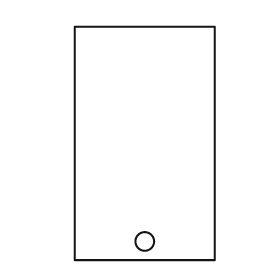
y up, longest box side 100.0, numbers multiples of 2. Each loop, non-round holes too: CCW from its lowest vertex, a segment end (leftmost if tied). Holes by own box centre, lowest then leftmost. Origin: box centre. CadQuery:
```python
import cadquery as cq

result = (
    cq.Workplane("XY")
    .moveTo(-30.0, -50.0)
    .lineTo(30.0, -50.0)
    .lineTo(30.0, 50.0)
    .lineTo(-30.0, 50.0)
    .close()
    .moveTo(0.0, -42.0)
    .circle(4.0)
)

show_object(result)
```